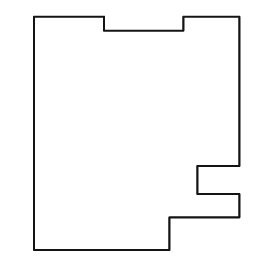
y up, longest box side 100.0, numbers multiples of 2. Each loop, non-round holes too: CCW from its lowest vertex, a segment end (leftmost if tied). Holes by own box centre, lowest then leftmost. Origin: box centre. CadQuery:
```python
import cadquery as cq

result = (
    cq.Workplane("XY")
    .moveTo(-44.0, -50.0)
    .lineTo(14.0, -50.0)
    .lineTo(14.0, -36.0)
    .lineTo(44.0, -36.0)
    .lineTo(44.0, -26.0)
    .lineTo(26.0, -26.0)
    .lineTo(26.0, -14.0)
    .lineTo(44.0, -14.0)
    .lineTo(44.0, 50.0)
    .lineTo(20.0, 50.0)
    .lineTo(20.0, 44.0)
    .lineTo(-14.0, 44.0)
    .lineTo(-14.0, 50.0)
    .lineTo(-44.0, 50.0)
    .close()
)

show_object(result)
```